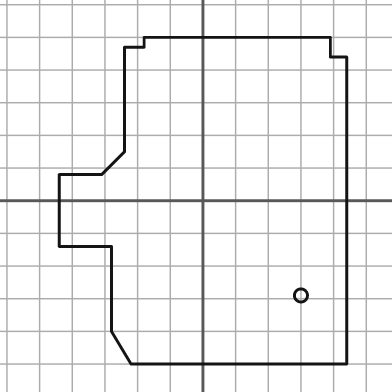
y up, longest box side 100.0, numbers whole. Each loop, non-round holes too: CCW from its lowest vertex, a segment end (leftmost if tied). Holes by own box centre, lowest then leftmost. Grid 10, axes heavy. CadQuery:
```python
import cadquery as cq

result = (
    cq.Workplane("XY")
    .moveTo(-22.0, -50.0)
    .lineTo(44.0, -50.0)
    .lineTo(44.0, 44.0)
    .lineTo(39.0, 44.0)
    .lineTo(39.0, 50.0)
    .lineTo(-18.0, 50.0)
    .lineTo(-18.0, 47.0)
    .lineTo(-24.0, 47.0)
    .lineTo(-24.0, 15.0)
    .lineTo(-31.0, 8.0)
    .lineTo(-44.0, 8.0)
    .lineTo(-44.0, -14.0)
    .lineTo(-28.0, -14.0)
    .lineTo(-28.0, -40.0)
    .close()
    .moveTo(30.0, -29.0)
    .circle(2.0)
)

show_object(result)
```